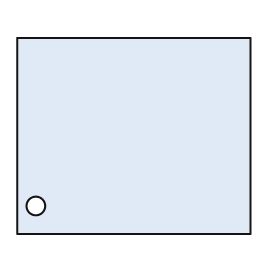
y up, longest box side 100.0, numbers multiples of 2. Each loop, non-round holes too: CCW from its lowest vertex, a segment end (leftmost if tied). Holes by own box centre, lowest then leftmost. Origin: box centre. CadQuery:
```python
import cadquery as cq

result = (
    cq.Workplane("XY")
    .moveTo(-50.0, -42.0)
    .lineTo(50.0, -42.0)
    .lineTo(50.0, 42.0)
    .lineTo(-50.0, 42.0)
    .close()
    .moveTo(-42.0, -30.0)
    .circle(4.0)
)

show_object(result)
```